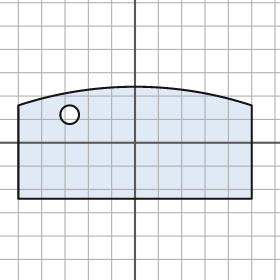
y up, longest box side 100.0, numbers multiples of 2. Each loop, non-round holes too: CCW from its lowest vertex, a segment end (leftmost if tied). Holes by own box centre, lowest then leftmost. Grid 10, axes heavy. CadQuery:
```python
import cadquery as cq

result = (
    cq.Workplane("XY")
    .moveTo(-50.0, -24.0)
    .lineTo(50.0, -24.0)
    .lineTo(50.0, 16.0)
    .threePointArc((0.0, 24.0), (-50.0, 16.0))
    .close()
    .moveTo(-28.0, 12.0)
    .circle(4.0)
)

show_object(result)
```